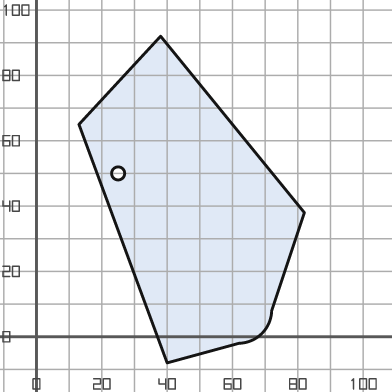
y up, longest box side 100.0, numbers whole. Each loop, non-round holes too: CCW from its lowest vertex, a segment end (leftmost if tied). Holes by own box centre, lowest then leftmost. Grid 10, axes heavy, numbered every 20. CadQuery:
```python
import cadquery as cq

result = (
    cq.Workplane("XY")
    .moveTo(40.0, -8.0)
    .lineTo(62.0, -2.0)
    .threePointArc((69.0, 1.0), (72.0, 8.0))
    .lineTo(82.0, 38.0)
    .lineTo(38.0, 92.0)
    .lineTo(13.0, 65.0)
    .close()
    .moveTo(25.0, 50.0)
    .circle(2.0)
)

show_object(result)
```